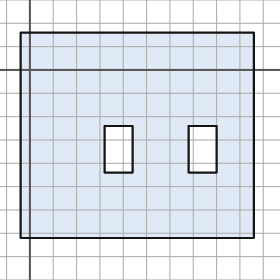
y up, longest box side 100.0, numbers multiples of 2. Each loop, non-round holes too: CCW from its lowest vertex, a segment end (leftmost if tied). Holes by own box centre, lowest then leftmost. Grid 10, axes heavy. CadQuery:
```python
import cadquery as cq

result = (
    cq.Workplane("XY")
    .moveTo(-4.0, -72.0)
    .lineTo(96.0, -72.0)
    .lineTo(96.0, 16.0)
    .lineTo(-4.0, 16.0)
    .close()
    .moveTo(32.0, -44.0)
    .lineTo(44.0, -44.0)
    .lineTo(44.0, -24.0)
    .lineTo(32.0, -24.0)
    .close()
    .moveTo(68.0, -44.0)
    .lineTo(80.0, -44.0)
    .lineTo(80.0, -24.0)
    .lineTo(68.0, -24.0)
    .close()
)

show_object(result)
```